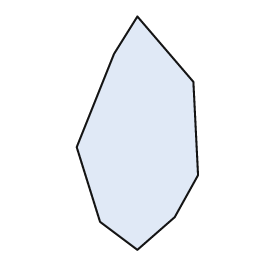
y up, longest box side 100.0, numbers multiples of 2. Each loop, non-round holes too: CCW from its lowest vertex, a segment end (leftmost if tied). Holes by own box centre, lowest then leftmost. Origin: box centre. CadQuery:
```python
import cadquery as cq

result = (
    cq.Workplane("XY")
    .moveTo(0.0, -50.0)
    .lineTo(16.0, -36.0)
    .lineTo(26.0, -18.0)
    .lineTo(24.0, 22.0)
    .lineTo(0.0, 50.0)
    .lineTo(-10.0, 34.0)
    .lineTo(-26.0, -6.0)
    .lineTo(-16.0, -38.0)
    .close()
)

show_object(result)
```